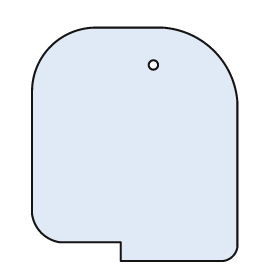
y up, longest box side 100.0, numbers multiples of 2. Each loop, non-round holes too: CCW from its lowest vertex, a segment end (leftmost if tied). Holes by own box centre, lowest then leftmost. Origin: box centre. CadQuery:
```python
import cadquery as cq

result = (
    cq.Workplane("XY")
    .moveTo(-6.0, -50.0)
    .lineTo(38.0, -50.0)
    .threePointArc((42.0, -48.0), (44.0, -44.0))
    .lineTo(44.0, 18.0)
    .threePointArc((34.0, 40.0), (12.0, 50.0))
    .lineTo(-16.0, 50.0)
    .threePointArc((-36.0, 42.0), (-44.0, 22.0))
    .lineTo(-44.0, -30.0)
    .threePointArc((-40.0, -38.0), (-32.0, -42.0))
    .lineTo(-6.0, -42.0)
    .close()
    .moveTo(8.0, 34.0)
    .circle(2.0)
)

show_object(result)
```